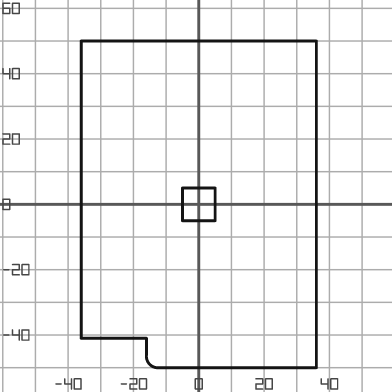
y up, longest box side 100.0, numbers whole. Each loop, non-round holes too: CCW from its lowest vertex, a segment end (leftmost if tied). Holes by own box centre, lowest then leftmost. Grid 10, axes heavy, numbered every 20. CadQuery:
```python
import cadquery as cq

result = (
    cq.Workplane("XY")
    .moveTo(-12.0, -50.0)
    .lineTo(36.0, -50.0)
    .lineTo(36.0, 50.0)
    .lineTo(-36.0, 50.0)
    .lineTo(-36.0, -41.0)
    .lineTo(-16.0, -41.0)
    .lineTo(-16.0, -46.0)
    .threePointArc((-15.0, -49.0), (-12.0, -50.0))
    .close()
    .moveTo(-5.0, -5.0)
    .lineTo(5.0, -5.0)
    .lineTo(5.0, 5.0)
    .lineTo(-5.0, 5.0)
    .close()
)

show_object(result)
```